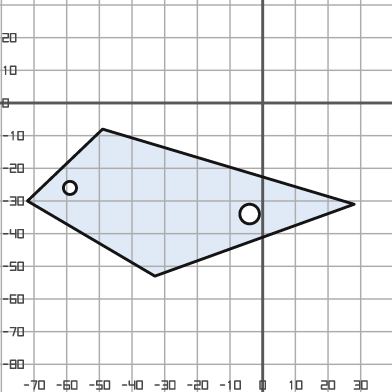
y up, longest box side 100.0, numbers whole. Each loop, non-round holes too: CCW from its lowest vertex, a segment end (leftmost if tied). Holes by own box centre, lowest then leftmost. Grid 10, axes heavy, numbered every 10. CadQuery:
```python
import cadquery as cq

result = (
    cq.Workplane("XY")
    .moveTo(-33.0, -53.0)
    .lineTo(28.0, -31.0)
    .lineTo(-49.0, -8.0)
    .lineTo(-72.0, -30.0)
    .close()
    .moveTo(-4.0, -34.0)
    .circle(3.0)
    .moveTo(-59.0, -26.0)
    .circle(2.0)
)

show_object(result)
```